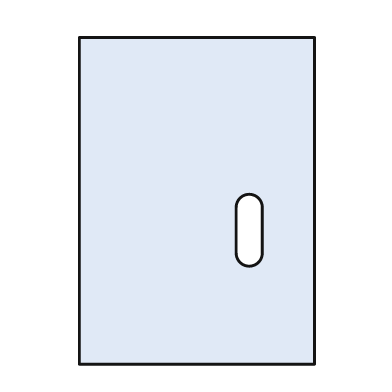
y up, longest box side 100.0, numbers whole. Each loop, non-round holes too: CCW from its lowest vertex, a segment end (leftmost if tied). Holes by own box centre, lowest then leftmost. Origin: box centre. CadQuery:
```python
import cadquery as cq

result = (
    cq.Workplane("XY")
    .moveTo(-36.0, -50.0)
    .lineTo(36.0, -50.0)
    .lineTo(36.0, 50.0)
    .lineTo(-36.0, 50.0)
    .close()
    .moveTo(12.0, -16.0)
    .threePointArc((16.0, -20.0), (20.0, -16.0))
    .lineTo(20.0, -2.0)
    .threePointArc((16.0, 2.0), (12.0, -2.0))
    .close()
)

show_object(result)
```